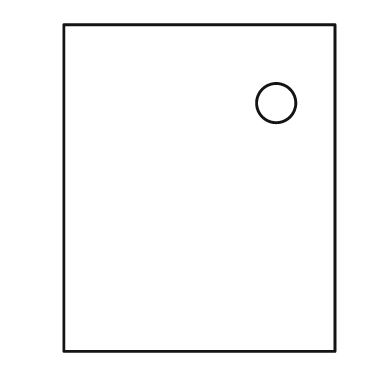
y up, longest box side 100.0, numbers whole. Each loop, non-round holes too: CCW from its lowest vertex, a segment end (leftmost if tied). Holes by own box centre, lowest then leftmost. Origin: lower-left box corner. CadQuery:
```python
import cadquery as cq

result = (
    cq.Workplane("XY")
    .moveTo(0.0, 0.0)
    .lineTo(83.0, 0.0)
    .lineTo(83.0, 100.0)
    .lineTo(0.0, 100.0)
    .close()
    .moveTo(65.0, 76.0)
    .circle(6.0)
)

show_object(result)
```